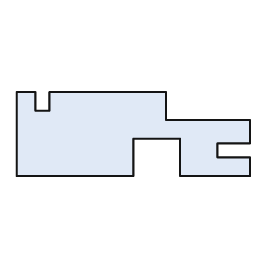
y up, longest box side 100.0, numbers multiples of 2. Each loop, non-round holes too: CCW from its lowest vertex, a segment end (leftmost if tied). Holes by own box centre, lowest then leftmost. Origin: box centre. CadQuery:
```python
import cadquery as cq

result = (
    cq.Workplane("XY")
    .moveTo(-50.0, -18.0)
    .lineTo(0.0, -18.0)
    .lineTo(0.0, -2.0)
    .lineTo(20.0, -2.0)
    .lineTo(20.0, -18.0)
    .lineTo(50.0, -18.0)
    .lineTo(50.0, -10.0)
    .lineTo(36.0, -10.0)
    .lineTo(36.0, -4.0)
    .lineTo(50.0, -4.0)
    .lineTo(50.0, 6.0)
    .lineTo(14.0, 6.0)
    .lineTo(14.0, 18.0)
    .lineTo(-36.0, 18.0)
    .lineTo(-36.0, 10.0)
    .lineTo(-42.0, 10.0)
    .lineTo(-42.0, 18.0)
    .lineTo(-50.0, 18.0)
    .close()
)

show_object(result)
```